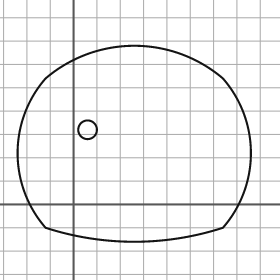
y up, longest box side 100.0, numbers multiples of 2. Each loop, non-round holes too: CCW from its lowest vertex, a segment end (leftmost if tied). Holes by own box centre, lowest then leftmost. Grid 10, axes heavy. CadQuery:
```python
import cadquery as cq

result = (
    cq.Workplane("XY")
    .moveTo(-12.0, -10.0)
    .threePointArc((26.0, -16.0), (64.0, -10.0))
    .threePointArc((76.0, 22.0), (64.0, 54.0))
    .threePointArc((26.0, 68.0), (-12.0, 54.0))
    .threePointArc((-24.0, 22.0), (-12.0, -10.0))
    .close()
    .moveTo(6.0, 32.0)
    .circle(4.0)
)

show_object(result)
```